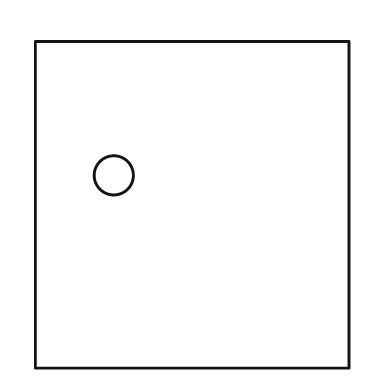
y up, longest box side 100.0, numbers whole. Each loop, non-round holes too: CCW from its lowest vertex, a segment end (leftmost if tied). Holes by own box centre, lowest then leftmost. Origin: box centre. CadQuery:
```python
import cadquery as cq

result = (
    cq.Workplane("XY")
    .moveTo(-48.0, -50.0)
    .lineTo(48.0, -50.0)
    .lineTo(48.0, 50.0)
    .lineTo(-48.0, 50.0)
    .close()
    .moveTo(-24.0, 9.0)
    .circle(6.0)
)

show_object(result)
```